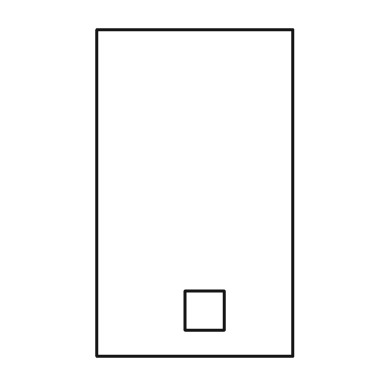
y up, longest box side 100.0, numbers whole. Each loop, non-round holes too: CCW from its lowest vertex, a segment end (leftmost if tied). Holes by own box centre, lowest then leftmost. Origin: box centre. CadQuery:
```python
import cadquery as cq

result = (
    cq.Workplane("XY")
    .moveTo(-30.0, -50.0)
    .lineTo(30.0, -50.0)
    .lineTo(30.0, 50.0)
    .lineTo(-30.0, 50.0)
    .close()
    .moveTo(-3.0, -42.0)
    .lineTo(9.0, -42.0)
    .lineTo(9.0, -30.0)
    .lineTo(-3.0, -30.0)
    .close()
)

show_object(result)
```